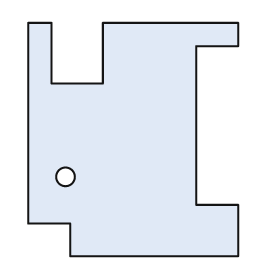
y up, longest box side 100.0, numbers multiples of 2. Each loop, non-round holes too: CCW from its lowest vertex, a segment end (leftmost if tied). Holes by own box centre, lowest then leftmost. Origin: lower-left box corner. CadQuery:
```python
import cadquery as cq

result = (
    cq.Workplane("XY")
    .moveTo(18.0, 0.0)
    .lineTo(90.0, 0.0)
    .lineTo(90.0, 22.0)
    .lineTo(72.0, 22.0)
    .lineTo(72.0, 90.0)
    .lineTo(90.0, 90.0)
    .lineTo(90.0, 100.0)
    .lineTo(32.0, 100.0)
    .lineTo(32.0, 74.0)
    .lineTo(10.0, 74.0)
    .lineTo(10.0, 100.0)
    .lineTo(0.0, 100.0)
    .lineTo(0.0, 14.0)
    .lineTo(18.0, 14.0)
    .close()
    .moveTo(16.0, 34.0)
    .circle(4.0)
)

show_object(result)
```